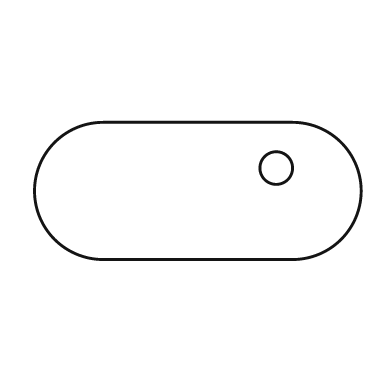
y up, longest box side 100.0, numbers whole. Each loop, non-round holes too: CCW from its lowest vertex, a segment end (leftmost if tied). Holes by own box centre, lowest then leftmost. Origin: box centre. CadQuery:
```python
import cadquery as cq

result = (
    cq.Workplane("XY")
    .moveTo(-29.0, -21.0)
    .lineTo(29.0, -21.0)
    .threePointArc((50.0, 0.0), (29.0, 21.0))
    .lineTo(-29.0, 21.0)
    .threePointArc((-50.0, 0.0), (-29.0, -21.0))
    .close()
    .moveTo(24.0, 7.0)
    .circle(5.0)
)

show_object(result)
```